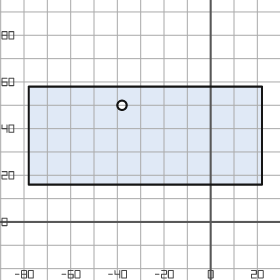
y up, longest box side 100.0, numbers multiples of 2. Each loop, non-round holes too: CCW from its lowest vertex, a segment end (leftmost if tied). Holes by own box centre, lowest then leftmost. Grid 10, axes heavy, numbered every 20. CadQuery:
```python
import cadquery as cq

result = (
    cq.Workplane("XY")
    .moveTo(-78.0, 16.0)
    .lineTo(22.0, 16.0)
    .lineTo(22.0, 58.0)
    .lineTo(-78.0, 58.0)
    .close()
    .moveTo(-38.0, 50.0)
    .circle(2.0)
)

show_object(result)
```